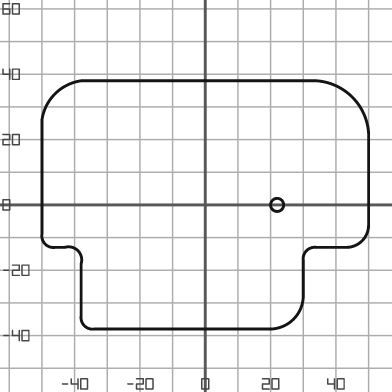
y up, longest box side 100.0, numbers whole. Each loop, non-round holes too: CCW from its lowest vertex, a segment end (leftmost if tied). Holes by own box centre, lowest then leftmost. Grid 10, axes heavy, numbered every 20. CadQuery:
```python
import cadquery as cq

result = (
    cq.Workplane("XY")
    .moveTo(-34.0, -38.0)
    .lineTo(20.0, -38.0)
    .threePointArc((27.0, -35.0), (30.0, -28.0))
    .lineTo(30.0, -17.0)
    .threePointArc((31.0, -14.0), (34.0, -13.0))
    .lineTo(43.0, -13.0)
    .threePointArc((48.0, -11.0), (50.0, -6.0))
    .lineTo(50.0, 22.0)
    .threePointArc((45.0, 33.0), (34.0, 38.0))
    .lineTo(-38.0, 38.0)
    .threePointArc((-46.0, 34.0), (-50.0, 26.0))
    .lineTo(-50.0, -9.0)
    .threePointArc((-49.0, -12.0), (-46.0, -13.0))
    .lineTo(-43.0, -13.0)
    .threePointArc((-39.0, -14.0), (-38.0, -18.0))
    .lineTo(-38.0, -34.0)
    .threePointArc((-37.0, -37.0), (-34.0, -38.0))
    .close()
    .moveTo(22.0, 0.0)
    .circle(2.0)
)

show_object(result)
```